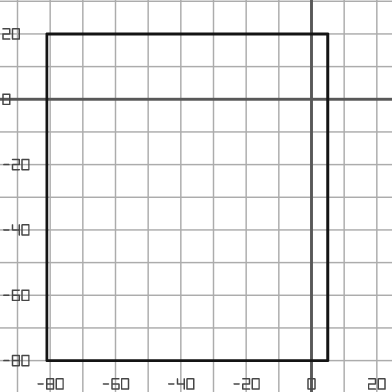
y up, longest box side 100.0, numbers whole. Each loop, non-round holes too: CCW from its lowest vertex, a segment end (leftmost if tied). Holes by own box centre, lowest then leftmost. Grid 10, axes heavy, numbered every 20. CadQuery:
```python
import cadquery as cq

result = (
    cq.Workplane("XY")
    .moveTo(-81.0, -80.0)
    .lineTo(5.0, -80.0)
    .lineTo(5.0, 20.0)
    .lineTo(-81.0, 20.0)
    .close()
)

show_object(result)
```